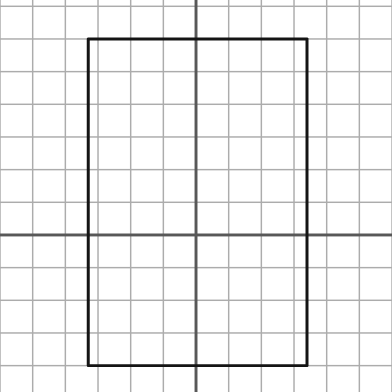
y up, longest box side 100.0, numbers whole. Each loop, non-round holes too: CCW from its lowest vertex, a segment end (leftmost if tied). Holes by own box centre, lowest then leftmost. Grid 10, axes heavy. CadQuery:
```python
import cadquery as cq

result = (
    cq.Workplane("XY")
    .moveTo(-33.0, -40.0)
    .lineTo(34.0, -40.0)
    .lineTo(34.0, 60.0)
    .lineTo(-33.0, 60.0)
    .close()
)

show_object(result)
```